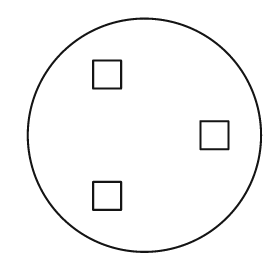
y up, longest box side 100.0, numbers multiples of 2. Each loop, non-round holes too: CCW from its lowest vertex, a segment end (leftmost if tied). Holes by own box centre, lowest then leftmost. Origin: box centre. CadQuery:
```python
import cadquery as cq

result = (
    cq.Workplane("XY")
    .moveTo(0.0, 0.0)
    .circle(50.0)
    .moveTo(-22.0, -32.0)
    .lineTo(-10.0, -32.0)
    .lineTo(-10.0, -20.0)
    .lineTo(-22.0, -20.0)
    .close()
    .moveTo(24.0, -6.0)
    .lineTo(36.0, -6.0)
    .lineTo(36.0, 6.0)
    .lineTo(24.0, 6.0)
    .close()
    .moveTo(-22.0, 20.0)
    .lineTo(-10.0, 20.0)
    .lineTo(-10.0, 32.0)
    .lineTo(-22.0, 32.0)
    .close()
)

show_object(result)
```